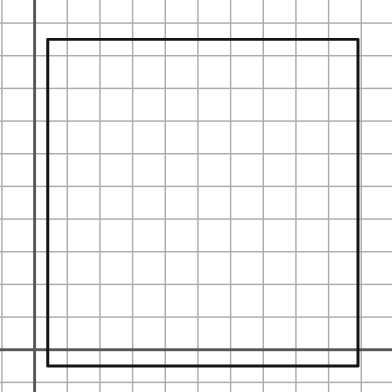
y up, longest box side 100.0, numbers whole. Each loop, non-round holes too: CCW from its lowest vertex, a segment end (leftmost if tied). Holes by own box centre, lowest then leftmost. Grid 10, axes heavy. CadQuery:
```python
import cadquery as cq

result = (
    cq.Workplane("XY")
    .moveTo(4.0, -5.0)
    .lineTo(99.0, -5.0)
    .lineTo(99.0, 95.0)
    .lineTo(4.0, 95.0)
    .close()
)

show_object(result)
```